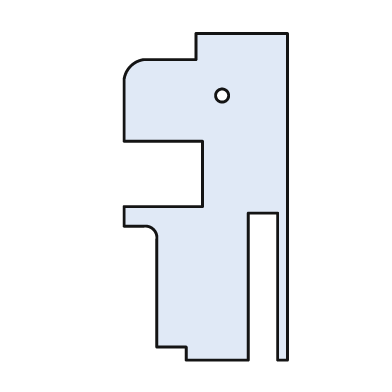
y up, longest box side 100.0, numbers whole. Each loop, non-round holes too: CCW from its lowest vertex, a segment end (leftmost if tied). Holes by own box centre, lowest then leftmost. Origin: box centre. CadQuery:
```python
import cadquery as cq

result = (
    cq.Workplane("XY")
    .moveTo(-6.0, -50.0)
    .lineTo(13.0, -50.0)
    .lineTo(13.0, -5.0)
    .lineTo(22.0, -5.0)
    .lineTo(22.0, -50.0)
    .lineTo(25.0, -50.0)
    .lineTo(25.0, 50.0)
    .lineTo(-3.0, 50.0)
    .lineTo(-3.0, 42.0)
    .lineTo(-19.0, 42.0)
    .threePointArc((-23.0, 40.0), (-25.0, 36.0))
    .lineTo(-25.0, 17.0)
    .lineTo(-1.0, 17.0)
    .lineTo(-1.0, -3.0)
    .lineTo(-25.0, -3.0)
    .lineTo(-25.0, -9.0)
    .lineTo(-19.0, -9.0)
    .threePointArc((-16.0, -10.0), (-15.0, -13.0))
    .lineTo(-15.0, -46.0)
    .lineTo(-6.0, -46.0)
    .close()
    .moveTo(5.0, 31.0)
    .circle(2.0)
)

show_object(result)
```